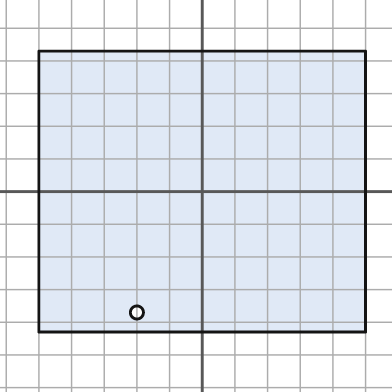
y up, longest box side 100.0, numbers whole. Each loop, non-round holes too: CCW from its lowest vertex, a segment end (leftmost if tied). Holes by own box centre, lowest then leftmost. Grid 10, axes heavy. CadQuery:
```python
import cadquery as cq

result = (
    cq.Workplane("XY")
    .moveTo(-50.0, -43.0)
    .lineTo(50.0, -43.0)
    .lineTo(50.0, 43.0)
    .lineTo(-50.0, 43.0)
    .close()
    .moveTo(-20.0, -37.0)
    .circle(2.0)
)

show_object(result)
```